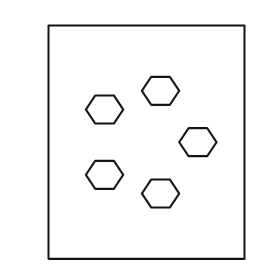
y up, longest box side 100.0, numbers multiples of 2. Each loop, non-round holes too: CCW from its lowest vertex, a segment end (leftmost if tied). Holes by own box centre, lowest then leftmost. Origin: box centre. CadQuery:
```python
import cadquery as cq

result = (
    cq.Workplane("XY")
    .moveTo(-42.0, -50.0)
    .lineTo(42.0, -50.0)
    .lineTo(42.0, 50.0)
    .lineTo(-42.0, 50.0)
    .close()
    .moveTo(2.0, -28.0)
    .lineTo(10.0, -28.0)
    .lineTo(14.0, -22.0)
    .lineTo(10.0, -16.0)
    .lineTo(2.0, -16.0)
    .lineTo(-2.0, -22.0)
    .close()
    .moveTo(-22.0, -20.0)
    .lineTo(-14.0, -20.0)
    .lineTo(-10.0, -14.0)
    .lineTo(-14.0, -8.0)
    .lineTo(-22.0, -8.0)
    .lineTo(-26.0, -14.0)
    .close()
    .moveTo(18.0, -6.0)
    .lineTo(26.0, -6.0)
    .lineTo(30.0, 0.0)
    .lineTo(26.0, 6.0)
    .lineTo(18.0, 6.0)
    .lineTo(14.0, 0.0)
    .close()
    .moveTo(-22.0, 8.0)
    .lineTo(-14.0, 8.0)
    .lineTo(-10.0, 14.0)
    .lineTo(-14.0, 20.0)
    .lineTo(-22.0, 20.0)
    .lineTo(-26.0, 14.0)
    .close()
    .moveTo(2.0, 16.0)
    .lineTo(10.0, 16.0)
    .lineTo(14.0, 22.0)
    .lineTo(10.0, 28.0)
    .lineTo(2.0, 28.0)
    .lineTo(-2.0, 22.0)
    .close()
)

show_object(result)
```